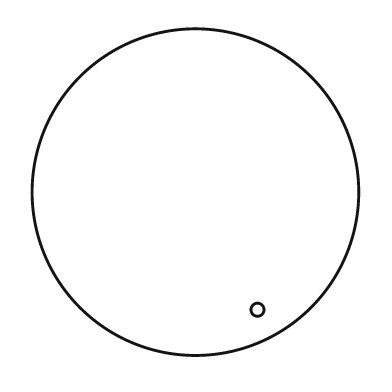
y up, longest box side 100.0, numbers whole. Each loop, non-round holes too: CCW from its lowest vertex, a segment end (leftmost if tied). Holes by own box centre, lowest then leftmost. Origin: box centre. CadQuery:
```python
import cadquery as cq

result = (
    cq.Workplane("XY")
    .moveTo(0.0, 0.0)
    .circle(50.0)
    .moveTo(19.0, -36.0)
    .circle(2.0)
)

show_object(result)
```